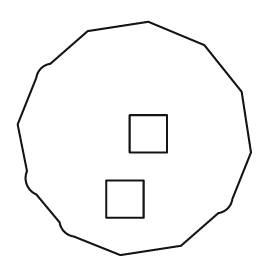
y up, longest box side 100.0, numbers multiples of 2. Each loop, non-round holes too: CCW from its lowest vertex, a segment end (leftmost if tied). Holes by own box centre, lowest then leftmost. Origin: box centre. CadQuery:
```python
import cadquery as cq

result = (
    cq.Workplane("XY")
    .moveTo(-6.0, -50.0)
    .lineTo(20.0, -46.0)
    .lineTo(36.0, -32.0)
    .threePointArc((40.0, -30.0), (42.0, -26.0))
    .lineTo(50.0, -6.0)
    .lineTo(46.0, 20.0)
    .lineTo(30.0, 40.0)
    .lineTo(6.0, 50.0)
    .lineTo(-20.0, 46.0)
    .lineTo(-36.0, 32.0)
    .threePointArc((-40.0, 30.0), (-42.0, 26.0))
    .lineTo(-50.0, 6.0)
    .lineTo(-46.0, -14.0)
    .threePointArc((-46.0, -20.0), (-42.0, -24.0))
    .lineTo(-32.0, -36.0)
    .threePointArc((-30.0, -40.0), (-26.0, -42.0))
    .close()
    .moveTo(-12.0, -34.0)
    .lineTo(4.0, -34.0)
    .lineTo(4.0, -18.0)
    .lineTo(-12.0, -18.0)
    .close()
    .moveTo(-2.0, -6.0)
    .lineTo(14.0, -6.0)
    .lineTo(14.0, 10.0)
    .lineTo(-2.0, 10.0)
    .close()
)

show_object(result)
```